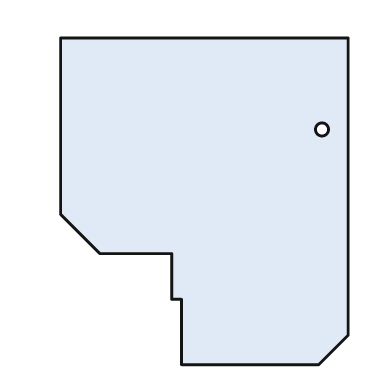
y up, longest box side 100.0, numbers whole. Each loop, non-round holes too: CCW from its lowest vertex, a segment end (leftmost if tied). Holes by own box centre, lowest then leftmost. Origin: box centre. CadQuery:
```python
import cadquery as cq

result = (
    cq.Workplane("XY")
    .moveTo(-7.0, -50.0)
    .lineTo(35.0, -50.0)
    .lineTo(44.0, -41.0)
    .lineTo(44.0, 50.0)
    .lineTo(-44.0, 50.0)
    .lineTo(-44.0, -4.0)
    .lineTo(-32.0, -16.0)
    .lineTo(-10.0, -16.0)
    .lineTo(-10.0, -30.0)
    .lineTo(-7.0, -30.0)
    .close()
    .moveTo(36.0, 22.0)
    .circle(2.0)
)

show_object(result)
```